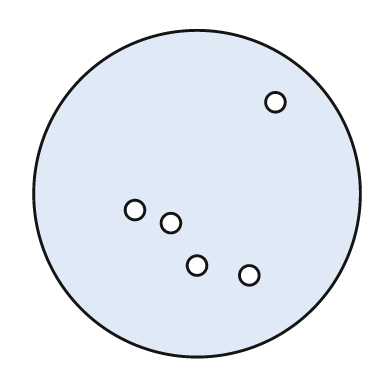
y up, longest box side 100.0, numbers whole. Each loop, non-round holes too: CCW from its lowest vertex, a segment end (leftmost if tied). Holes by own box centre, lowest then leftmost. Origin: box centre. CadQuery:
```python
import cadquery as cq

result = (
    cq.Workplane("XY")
    .moveTo(0.0, 0.0)
    .circle(50.0)
    .moveTo(16.0, -25.0)
    .circle(3.0)
    .moveTo(0.0, -22.0)
    .circle(3.0)
    .moveTo(-8.0, -9.0)
    .circle(3.0)
    .moveTo(-19.0, -5.0)
    .circle(3.0)
    .moveTo(24.0, 28.0)
    .circle(3.0)
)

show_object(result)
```